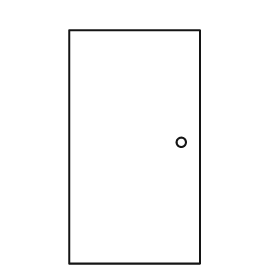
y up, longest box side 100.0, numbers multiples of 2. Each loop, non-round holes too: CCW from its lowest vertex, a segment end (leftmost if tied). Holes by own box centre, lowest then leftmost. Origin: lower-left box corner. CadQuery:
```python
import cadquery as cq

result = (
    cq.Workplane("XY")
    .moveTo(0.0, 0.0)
    .lineTo(56.0, 0.0)
    .lineTo(56.0, 100.0)
    .lineTo(0.0, 100.0)
    .close()
    .moveTo(48.0, 52.0)
    .circle(2.0)
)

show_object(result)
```